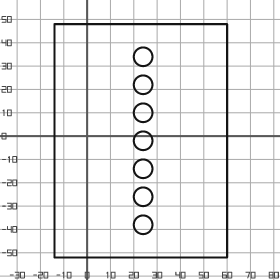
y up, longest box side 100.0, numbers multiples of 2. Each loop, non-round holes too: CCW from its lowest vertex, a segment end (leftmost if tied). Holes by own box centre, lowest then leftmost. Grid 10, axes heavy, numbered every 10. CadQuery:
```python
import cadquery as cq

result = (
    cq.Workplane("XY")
    .moveTo(-14.0, -52.0)
    .lineTo(60.0, -52.0)
    .lineTo(60.0, 48.0)
    .lineTo(-14.0, 48.0)
    .close()
    .moveTo(24.0, -38.0)
    .circle(4.0)
    .moveTo(24.0, -26.0)
    .circle(4.0)
    .moveTo(24.0, -14.0)
    .circle(4.0)
    .moveTo(24.0, -2.0)
    .circle(4.0)
    .moveTo(24.0, 10.0)
    .circle(4.0)
    .moveTo(24.0, 22.0)
    .circle(4.0)
    .moveTo(24.0, 34.0)
    .circle(4.0)
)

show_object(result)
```